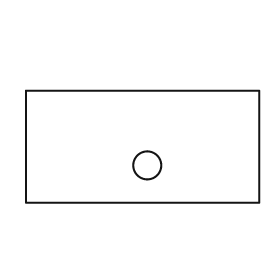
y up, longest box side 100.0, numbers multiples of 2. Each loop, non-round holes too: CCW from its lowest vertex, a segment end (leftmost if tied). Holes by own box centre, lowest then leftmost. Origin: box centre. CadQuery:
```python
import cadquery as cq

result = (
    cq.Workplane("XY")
    .moveTo(-50.0, -24.0)
    .lineTo(50.0, -24.0)
    .lineTo(50.0, 24.0)
    .lineTo(-50.0, 24.0)
    .close()
    .moveTo(2.0, -8.0)
    .circle(6.0)
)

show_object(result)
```